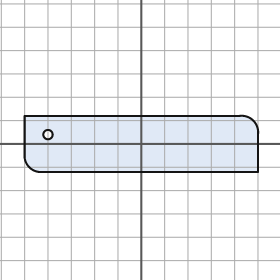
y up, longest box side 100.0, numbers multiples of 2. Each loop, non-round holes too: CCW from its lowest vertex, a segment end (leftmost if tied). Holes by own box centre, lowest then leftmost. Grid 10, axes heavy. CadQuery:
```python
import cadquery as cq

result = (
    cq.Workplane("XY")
    .moveTo(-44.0, -12.0)
    .lineTo(50.0, -12.0)
    .lineTo(50.0, 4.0)
    .threePointArc((48.0, 10.0), (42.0, 12.0))
    .lineTo(-50.0, 12.0)
    .lineTo(-50.0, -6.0)
    .threePointArc((-48.0, -10.0), (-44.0, -12.0))
    .close()
    .moveTo(-40.0, 4.0)
    .circle(2.0)
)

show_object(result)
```